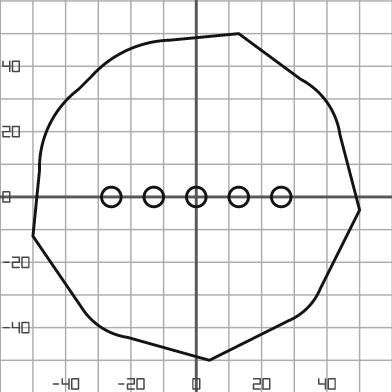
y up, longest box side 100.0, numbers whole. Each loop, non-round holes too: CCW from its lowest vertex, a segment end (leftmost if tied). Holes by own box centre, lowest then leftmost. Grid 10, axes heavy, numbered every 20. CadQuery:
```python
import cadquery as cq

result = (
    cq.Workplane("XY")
    .moveTo(4.0, -50.0)
    .lineTo(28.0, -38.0)
    .threePointArc((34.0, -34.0), (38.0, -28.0))
    .lineTo(50.0, -4.0)
    .lineTo(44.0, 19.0)
    .threePointArc((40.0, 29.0), (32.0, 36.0))
    .lineTo(13.0, 50.0)
    .lineTo(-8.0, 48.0)
    .threePointArc((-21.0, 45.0), (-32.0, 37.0))
    .lineTo(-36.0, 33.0)
    .threePointArc((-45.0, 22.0), (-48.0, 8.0))
    .lineTo(-50.0, -12.0)
    .lineTo(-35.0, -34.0)
    .threePointArc((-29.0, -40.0), (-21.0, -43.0))
    .close()
    .moveTo(-26.0, 0.0)
    .circle(3.0)
    .moveTo(-13.0, 0.0)
    .circle(3.0)
    .moveTo(0.0, 0.0)
    .circle(3.0)
    .moveTo(13.0, 0.0)
    .circle(3.0)
    .moveTo(26.0, 0.0)
    .circle(3.0)
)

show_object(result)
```